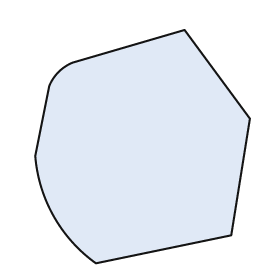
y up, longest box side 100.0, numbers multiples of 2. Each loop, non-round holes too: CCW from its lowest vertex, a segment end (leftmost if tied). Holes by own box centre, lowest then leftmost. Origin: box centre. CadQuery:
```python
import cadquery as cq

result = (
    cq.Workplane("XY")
    .moveTo(-20.0, -50.0)
    .lineTo(38.0, -38.0)
    .lineTo(46.0, 12.0)
    .lineTo(18.0, 50.0)
    .lineTo(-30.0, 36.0)
    .threePointArc((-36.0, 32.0), (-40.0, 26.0))
    .lineTo(-46.0, -4.0)
    .threePointArc((-38.0, -30.0), (-20.0, -50.0))
    .close()
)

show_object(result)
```